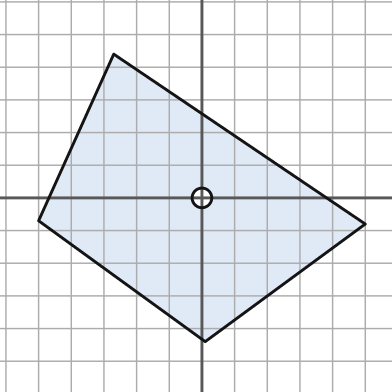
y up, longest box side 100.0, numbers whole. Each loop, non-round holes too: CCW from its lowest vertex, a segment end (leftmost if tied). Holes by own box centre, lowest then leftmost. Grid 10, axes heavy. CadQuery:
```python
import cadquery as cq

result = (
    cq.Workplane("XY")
    .moveTo(1.0, -44.0)
    .lineTo(50.0, -8.0)
    .lineTo(-27.0, 44.0)
    .lineTo(-50.0, -7.0)
    .close()
    .moveTo(0.0, 0.0)
    .circle(3.0)
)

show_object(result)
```